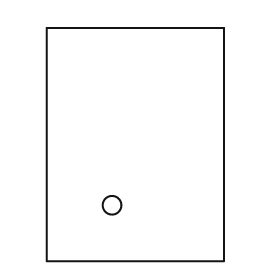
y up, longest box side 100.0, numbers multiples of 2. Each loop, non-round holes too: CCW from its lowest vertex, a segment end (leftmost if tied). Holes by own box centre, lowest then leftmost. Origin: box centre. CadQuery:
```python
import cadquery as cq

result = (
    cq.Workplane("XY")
    .moveTo(-38.0, -50.0)
    .lineTo(38.0, -50.0)
    .lineTo(38.0, 50.0)
    .lineTo(-38.0, 50.0)
    .close()
    .moveTo(-10.0, -26.0)
    .circle(4.0)
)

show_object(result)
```